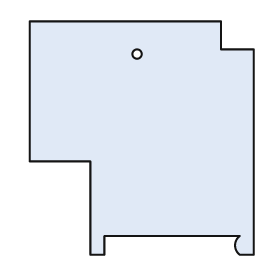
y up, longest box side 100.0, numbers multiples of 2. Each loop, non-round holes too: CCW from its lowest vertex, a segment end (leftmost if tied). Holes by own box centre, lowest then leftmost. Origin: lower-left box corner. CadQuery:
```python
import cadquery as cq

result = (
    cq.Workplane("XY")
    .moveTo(26.0, 0.0)
    .lineTo(32.0, 0.0)
    .lineTo(32.0, 8.0)
    .lineTo(90.0, 8.0)
    .threePointArc((88.0, 4.0), (90.0, 0.0))
    .lineTo(96.0, 0.0)
    .lineTo(96.0, 88.0)
    .lineTo(82.0, 88.0)
    .lineTo(82.0, 100.0)
    .lineTo(0.0, 100.0)
    .lineTo(0.0, 40.0)
    .lineTo(26.0, 40.0)
    .close()
    .moveTo(46.0, 86.0)
    .circle(2.0)
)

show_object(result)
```